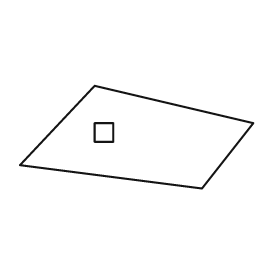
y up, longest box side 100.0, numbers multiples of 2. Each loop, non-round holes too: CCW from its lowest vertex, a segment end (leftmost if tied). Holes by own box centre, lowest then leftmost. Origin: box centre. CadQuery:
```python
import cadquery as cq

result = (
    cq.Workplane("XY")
    .moveTo(28.0, -22.0)
    .lineTo(50.0, 6.0)
    .lineTo(-18.0, 22.0)
    .lineTo(-50.0, -12.0)
    .close()
    .moveTo(-18.0, -2.0)
    .lineTo(-10.0, -2.0)
    .lineTo(-10.0, 6.0)
    .lineTo(-18.0, 6.0)
    .close()
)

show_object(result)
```